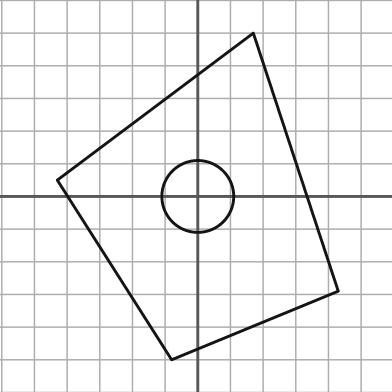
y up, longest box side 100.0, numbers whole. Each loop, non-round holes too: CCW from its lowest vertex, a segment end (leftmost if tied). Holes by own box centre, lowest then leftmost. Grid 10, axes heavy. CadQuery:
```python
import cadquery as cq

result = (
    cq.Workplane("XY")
    .moveTo(-8.0, -50.0)
    .lineTo(43.0, -29.0)
    .lineTo(17.0, 50.0)
    .lineTo(-43.0, 5.0)
    .close()
    .moveTo(0.0, 0.0)
    .circle(11.0)
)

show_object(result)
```